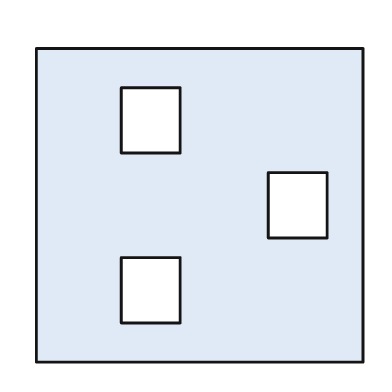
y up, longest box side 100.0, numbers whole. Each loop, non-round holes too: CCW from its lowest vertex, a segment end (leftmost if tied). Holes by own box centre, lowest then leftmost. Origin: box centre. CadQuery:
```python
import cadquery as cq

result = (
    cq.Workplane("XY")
    .moveTo(-50.0, -48.0)
    .lineTo(50.0, -48.0)
    .lineTo(50.0, 48.0)
    .lineTo(-50.0, 48.0)
    .close()
    .moveTo(-24.0, -36.0)
    .lineTo(-6.0, -36.0)
    .lineTo(-6.0, -16.0)
    .lineTo(-24.0, -16.0)
    .close()
    .moveTo(21.0, -10.0)
    .lineTo(39.0, -10.0)
    .lineTo(39.0, 10.0)
    .lineTo(21.0, 10.0)
    .close()
    .moveTo(-24.0, 16.0)
    .lineTo(-6.0, 16.0)
    .lineTo(-6.0, 36.0)
    .lineTo(-24.0, 36.0)
    .close()
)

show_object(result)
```